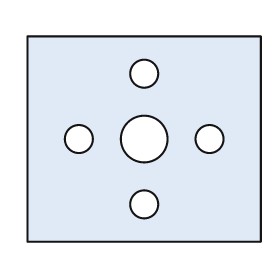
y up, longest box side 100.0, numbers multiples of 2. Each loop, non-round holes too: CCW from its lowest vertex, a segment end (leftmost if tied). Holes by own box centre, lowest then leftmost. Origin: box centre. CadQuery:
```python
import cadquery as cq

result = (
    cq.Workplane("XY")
    .moveTo(-50.0, -44.0)
    .lineTo(50.0, -44.0)
    .lineTo(50.0, 44.0)
    .lineTo(-50.0, 44.0)
    .close()
    .moveTo(0.0, -28.0)
    .circle(6.0)
    .moveTo(-28.0, 0.0)
    .circle(6.0)
    .moveTo(0.0, 0.0)
    .circle(10.0)
    .moveTo(28.0, 0.0)
    .circle(6.0)
    .moveTo(0.0, 28.0)
    .circle(6.0)
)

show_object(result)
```